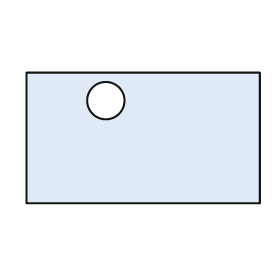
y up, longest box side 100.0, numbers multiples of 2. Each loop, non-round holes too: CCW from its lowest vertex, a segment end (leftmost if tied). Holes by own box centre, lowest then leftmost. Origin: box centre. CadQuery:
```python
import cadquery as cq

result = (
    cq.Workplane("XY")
    .moveTo(-50.0, -28.0)
    .lineTo(50.0, -28.0)
    .lineTo(50.0, 28.0)
    .lineTo(-50.0, 28.0)
    .close()
    .moveTo(-16.0, 16.0)
    .circle(8.0)
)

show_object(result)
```